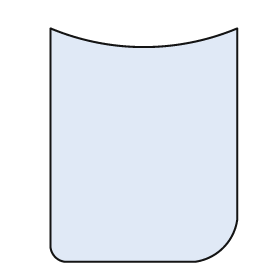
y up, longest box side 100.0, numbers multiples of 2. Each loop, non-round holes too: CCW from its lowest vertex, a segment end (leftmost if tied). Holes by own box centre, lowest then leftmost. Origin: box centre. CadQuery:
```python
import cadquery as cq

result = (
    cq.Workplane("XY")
    .moveTo(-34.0, -50.0)
    .lineTo(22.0, -50.0)
    .threePointArc((34.0, -44.0), (40.0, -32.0))
    .lineTo(40.0, 50.0)
    .threePointArc((0.0, 42.0), (-40.0, 50.0))
    .lineTo(-40.0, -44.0)
    .threePointArc((-38.0, -48.0), (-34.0, -50.0))
    .close()
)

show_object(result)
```